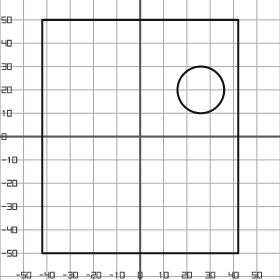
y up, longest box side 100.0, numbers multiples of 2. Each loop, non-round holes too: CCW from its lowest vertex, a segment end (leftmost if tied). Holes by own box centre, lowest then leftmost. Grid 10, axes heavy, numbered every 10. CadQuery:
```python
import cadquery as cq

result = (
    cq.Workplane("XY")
    .moveTo(-42.0, -50.0)
    .lineTo(42.0, -50.0)
    .lineTo(42.0, 50.0)
    .lineTo(-42.0, 50.0)
    .close()
    .moveTo(26.0, 20.0)
    .circle(10.0)
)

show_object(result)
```